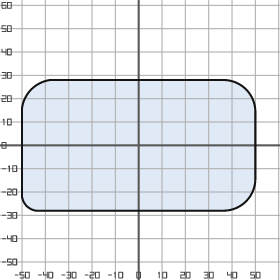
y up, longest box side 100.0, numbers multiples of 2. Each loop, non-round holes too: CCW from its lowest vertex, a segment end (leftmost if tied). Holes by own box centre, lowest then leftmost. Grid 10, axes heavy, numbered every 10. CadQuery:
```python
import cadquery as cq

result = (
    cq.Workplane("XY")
    .moveTo(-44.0, -28.0)
    .lineTo(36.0, -28.0)
    .threePointArc((46.0, -24.0), (50.0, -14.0))
    .lineTo(50.0, 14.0)
    .threePointArc((46.0, 24.0), (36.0, 28.0))
    .lineTo(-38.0, 28.0)
    .threePointArc((-46.0, 24.0), (-50.0, 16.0))
    .lineTo(-50.0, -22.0)
    .threePointArc((-48.0, -26.0), (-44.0, -28.0))
    .close()
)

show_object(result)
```